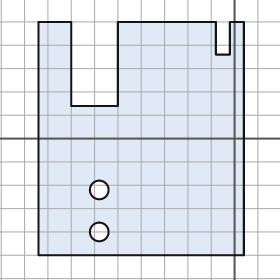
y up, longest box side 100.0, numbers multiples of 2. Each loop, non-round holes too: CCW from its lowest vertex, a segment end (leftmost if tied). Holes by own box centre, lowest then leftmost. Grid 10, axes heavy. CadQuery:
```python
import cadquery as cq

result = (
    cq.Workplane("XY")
    .moveTo(-84.0, -50.0)
    .lineTo(4.0, -50.0)
    .lineTo(4.0, 50.0)
    .lineTo(-2.0, 50.0)
    .lineTo(-2.0, 36.0)
    .lineTo(-8.0, 36.0)
    .lineTo(-8.0, 50.0)
    .lineTo(-50.0, 50.0)
    .lineTo(-50.0, 14.0)
    .lineTo(-70.0, 14.0)
    .lineTo(-70.0, 50.0)
    .lineTo(-84.0, 50.0)
    .close()
    .moveTo(-58.0, -40.0)
    .circle(4.0)
    .moveTo(-58.0, -22.0)
    .circle(4.0)
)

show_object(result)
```